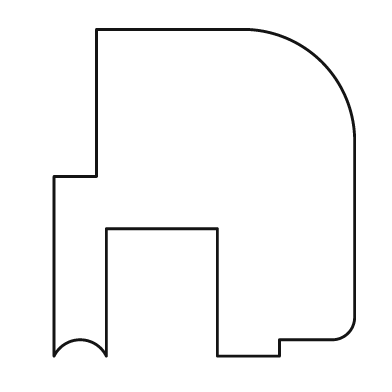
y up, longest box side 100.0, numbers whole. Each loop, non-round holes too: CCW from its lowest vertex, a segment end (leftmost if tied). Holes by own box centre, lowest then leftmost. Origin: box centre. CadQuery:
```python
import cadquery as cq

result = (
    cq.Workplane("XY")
    .moveTo(-46.0, -50.0)
    .threePointArc((-38.0, -45.0), (-30.0, -50.0))
    .lineTo(-30.0, -11.0)
    .lineTo(4.0, -11.0)
    .lineTo(4.0, -50.0)
    .lineTo(23.0, -50.0)
    .lineTo(23.0, -45.0)
    .lineTo(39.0, -45.0)
    .threePointArc((44.0, -43.0), (46.0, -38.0))
    .lineTo(46.0, 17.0)
    .threePointArc((36.0, 40.0), (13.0, 50.0))
    .lineTo(-33.0, 50.0)
    .lineTo(-33.0, 5.0)
    .lineTo(-46.0, 5.0)
    .close()
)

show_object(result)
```